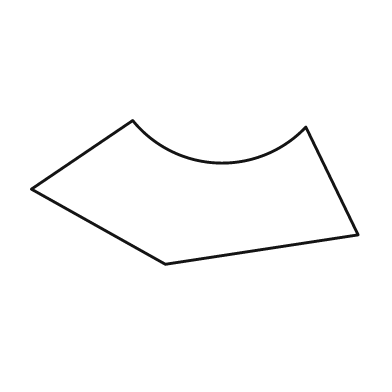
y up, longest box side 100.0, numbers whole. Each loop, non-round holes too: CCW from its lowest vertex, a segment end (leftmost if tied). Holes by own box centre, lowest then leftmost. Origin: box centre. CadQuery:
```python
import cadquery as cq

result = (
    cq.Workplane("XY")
    .moveTo(-9.0, -22.0)
    .lineTo(50.0, -13.0)
    .lineTo(34.0, 20.0)
    .threePointArc((7.0, 9.0), (-19.0, 22.0))
    .lineTo(-50.0, 1.0)
    .close()
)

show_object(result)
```